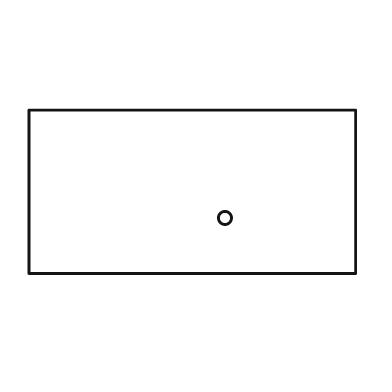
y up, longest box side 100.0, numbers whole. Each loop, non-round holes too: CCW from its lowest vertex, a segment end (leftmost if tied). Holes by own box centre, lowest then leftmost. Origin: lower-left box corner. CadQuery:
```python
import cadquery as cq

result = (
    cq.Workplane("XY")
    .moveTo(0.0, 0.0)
    .lineTo(100.0, 0.0)
    .lineTo(100.0, 50.0)
    .lineTo(0.0, 50.0)
    .close()
    .moveTo(60.0, 17.0)
    .circle(2.0)
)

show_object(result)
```